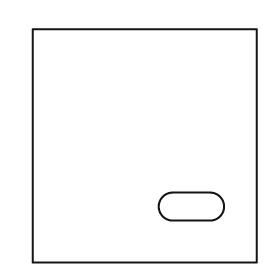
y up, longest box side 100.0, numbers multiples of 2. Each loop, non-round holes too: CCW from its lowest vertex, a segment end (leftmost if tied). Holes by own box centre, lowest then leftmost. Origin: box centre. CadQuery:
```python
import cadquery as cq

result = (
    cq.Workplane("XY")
    .moveTo(-48.0, -50.0)
    .lineTo(48.0, -50.0)
    .lineTo(48.0, 50.0)
    .lineTo(-48.0, 50.0)
    .close()
    .moveTo(12.0, -32.0)
    .lineTo(28.0, -32.0)
    .threePointArc((34.0, -26.0), (28.0, -20.0))
    .lineTo(12.0, -20.0)
    .threePointArc((6.0, -26.0), (12.0, -32.0))
    .close()
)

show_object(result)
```